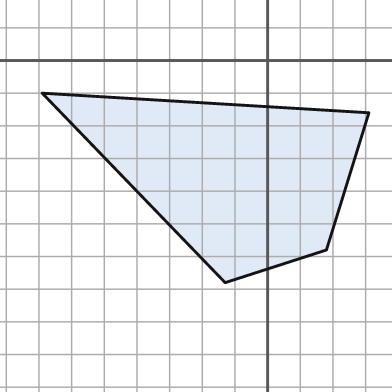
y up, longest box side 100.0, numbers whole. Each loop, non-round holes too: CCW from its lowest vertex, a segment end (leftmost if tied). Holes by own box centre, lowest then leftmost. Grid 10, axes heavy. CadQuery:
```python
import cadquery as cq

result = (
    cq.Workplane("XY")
    .moveTo(-13.0, -68.0)
    .lineTo(18.0, -58.0)
    .lineTo(31.0, -16.0)
    .lineTo(-69.0, -10.0)
    .close()
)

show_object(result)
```